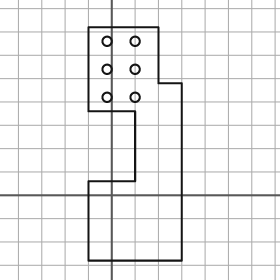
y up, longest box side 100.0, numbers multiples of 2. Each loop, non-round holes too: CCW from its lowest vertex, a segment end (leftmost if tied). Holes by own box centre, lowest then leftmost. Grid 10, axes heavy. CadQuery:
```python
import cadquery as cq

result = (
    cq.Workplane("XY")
    .moveTo(-10.0, -28.0)
    .lineTo(30.0, -28.0)
    .lineTo(30.0, 48.0)
    .lineTo(20.0, 48.0)
    .lineTo(20.0, 72.0)
    .lineTo(-10.0, 72.0)
    .lineTo(-10.0, 36.0)
    .lineTo(10.0, 36.0)
    .lineTo(10.0, 6.0)
    .lineTo(-10.0, 6.0)
    .close()
    .moveTo(-2.0, 42.0)
    .circle(2.0)
    .moveTo(10.0, 42.0)
    .circle(2.0)
    .moveTo(-2.0, 54.0)
    .circle(2.0)
    .moveTo(10.0, 54.0)
    .circle(2.0)
    .moveTo(-2.0, 66.0)
    .circle(2.0)
    .moveTo(10.0, 66.0)
    .circle(2.0)
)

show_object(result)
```